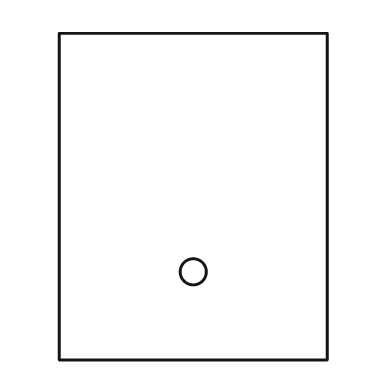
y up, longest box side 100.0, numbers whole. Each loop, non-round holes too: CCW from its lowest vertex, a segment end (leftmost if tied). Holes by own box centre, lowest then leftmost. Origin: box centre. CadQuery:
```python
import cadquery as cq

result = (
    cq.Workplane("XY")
    .moveTo(-41.0, -50.0)
    .lineTo(41.0, -50.0)
    .lineTo(41.0, 50.0)
    .lineTo(-41.0, 50.0)
    .close()
    .moveTo(0.0, -23.0)
    .circle(4.0)
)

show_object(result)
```